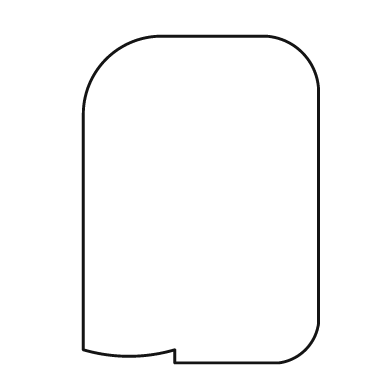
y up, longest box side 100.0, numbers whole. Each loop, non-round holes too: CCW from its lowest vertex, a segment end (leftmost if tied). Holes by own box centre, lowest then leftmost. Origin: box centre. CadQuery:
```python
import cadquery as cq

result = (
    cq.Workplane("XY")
    .moveTo(-8.0, -50.0)
    .lineTo(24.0, -50.0)
    .threePointArc((32.0, -46.0), (36.0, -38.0))
    .lineTo(36.0, 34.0)
    .threePointArc((31.0, 45.0), (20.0, 50.0))
    .lineTo(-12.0, 50.0)
    .threePointArc((-29.0, 43.0), (-36.0, 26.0))
    .lineTo(-36.0, -46.0)
    .threePointArc((-22.0, -48.0), (-8.0, -46.0))
    .close()
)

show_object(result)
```